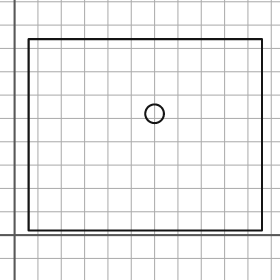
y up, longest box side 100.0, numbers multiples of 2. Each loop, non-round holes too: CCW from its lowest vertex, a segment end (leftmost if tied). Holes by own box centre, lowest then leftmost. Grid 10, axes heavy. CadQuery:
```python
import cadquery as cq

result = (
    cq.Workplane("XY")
    .moveTo(6.0, 2.0)
    .lineTo(106.0, 2.0)
    .lineTo(106.0, 84.0)
    .lineTo(6.0, 84.0)
    .close()
    .moveTo(60.0, 52.0)
    .circle(4.0)
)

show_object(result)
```